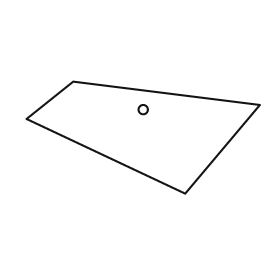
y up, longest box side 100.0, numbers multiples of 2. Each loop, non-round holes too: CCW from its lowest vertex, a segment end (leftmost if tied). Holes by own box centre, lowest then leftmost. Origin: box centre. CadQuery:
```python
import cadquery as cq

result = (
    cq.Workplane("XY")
    .moveTo(18.0, -24.0)
    .lineTo(50.0, 14.0)
    .lineTo(-30.0, 24.0)
    .lineTo(-50.0, 8.0)
    .close()
    .moveTo(0.0, 12.0)
    .circle(2.0)
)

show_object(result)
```